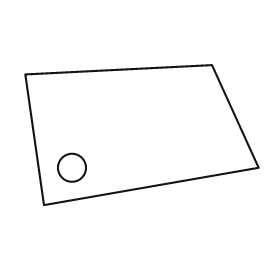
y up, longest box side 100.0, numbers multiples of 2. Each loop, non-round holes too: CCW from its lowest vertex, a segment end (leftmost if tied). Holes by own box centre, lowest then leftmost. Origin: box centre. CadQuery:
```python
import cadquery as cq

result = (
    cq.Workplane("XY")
    .moveTo(-42.0, -30.0)
    .lineTo(50.0, -14.0)
    .lineTo(30.0, 30.0)
    .lineTo(-50.0, 26.0)
    .close()
    .moveTo(-30.0, -14.0)
    .circle(6.0)
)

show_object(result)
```